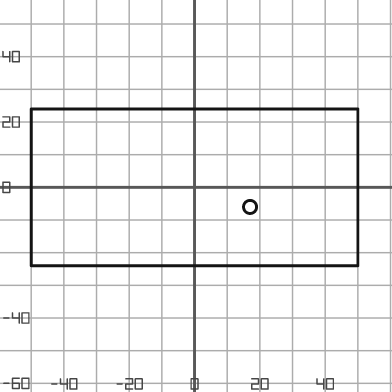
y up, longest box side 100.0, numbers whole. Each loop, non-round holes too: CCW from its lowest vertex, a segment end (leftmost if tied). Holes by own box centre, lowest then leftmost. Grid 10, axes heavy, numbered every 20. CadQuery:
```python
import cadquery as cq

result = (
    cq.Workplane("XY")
    .moveTo(-50.0, -24.0)
    .lineTo(50.0, -24.0)
    .lineTo(50.0, 24.0)
    .lineTo(-50.0, 24.0)
    .close()
    .moveTo(17.0, -6.0)
    .circle(2.0)
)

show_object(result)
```